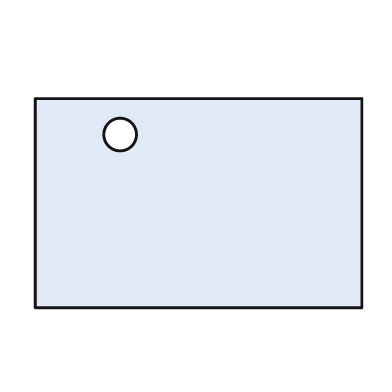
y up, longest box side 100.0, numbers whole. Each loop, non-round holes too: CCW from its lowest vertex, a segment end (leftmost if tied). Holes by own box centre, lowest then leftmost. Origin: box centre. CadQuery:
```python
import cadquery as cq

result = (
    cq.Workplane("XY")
    .moveTo(-50.0, -32.0)
    .lineTo(50.0, -32.0)
    .lineTo(50.0, 32.0)
    .lineTo(-50.0, 32.0)
    .close()
    .moveTo(-24.0, 21.0)
    .circle(5.0)
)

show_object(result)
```